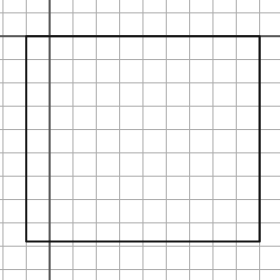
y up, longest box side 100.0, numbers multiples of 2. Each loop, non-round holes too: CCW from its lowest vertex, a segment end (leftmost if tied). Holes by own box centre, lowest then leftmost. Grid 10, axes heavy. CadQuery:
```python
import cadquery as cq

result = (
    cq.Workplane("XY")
    .moveTo(-10.0, -88.0)
    .lineTo(90.0, -88.0)
    .lineTo(90.0, 0.0)
    .lineTo(-10.0, 0.0)
    .close()
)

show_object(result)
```